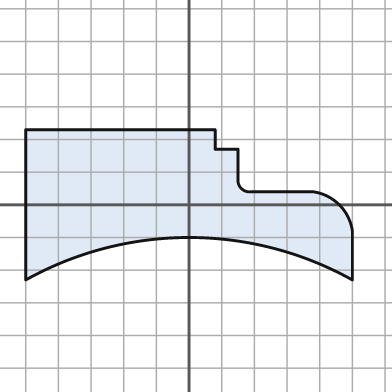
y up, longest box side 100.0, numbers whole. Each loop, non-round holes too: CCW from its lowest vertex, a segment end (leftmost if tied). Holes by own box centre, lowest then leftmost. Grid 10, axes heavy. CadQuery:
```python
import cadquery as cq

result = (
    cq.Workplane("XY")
    .moveTo(-50.0, -23.0)
    .threePointArc((0.0, -10.0), (50.0, -23.0))
    .lineTo(50.0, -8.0)
    .threePointArc((46.0, 0.0), (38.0, 4.0))
    .lineTo(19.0, 4.0)
    .threePointArc((16.0, 5.0), (15.0, 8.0))
    .lineTo(15.0, 17.0)
    .lineTo(8.0, 17.0)
    .lineTo(8.0, 23.0)
    .lineTo(-50.0, 23.0)
    .close()
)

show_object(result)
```